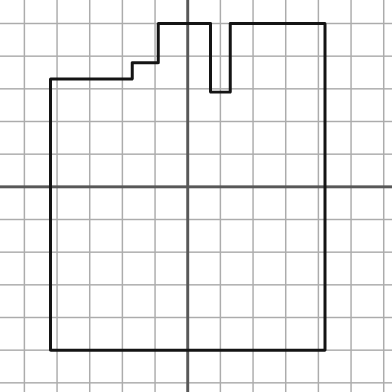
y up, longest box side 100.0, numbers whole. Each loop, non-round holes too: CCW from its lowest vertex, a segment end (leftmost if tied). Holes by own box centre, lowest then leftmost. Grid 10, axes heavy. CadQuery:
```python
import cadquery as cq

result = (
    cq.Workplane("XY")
    .moveTo(-42.0, -50.0)
    .lineTo(42.0, -50.0)
    .lineTo(42.0, 50.0)
    .lineTo(13.0, 50.0)
    .lineTo(13.0, 29.0)
    .lineTo(7.0, 29.0)
    .lineTo(7.0, 50.0)
    .lineTo(-9.0, 50.0)
    .lineTo(-9.0, 38.0)
    .lineTo(-17.0, 38.0)
    .lineTo(-17.0, 33.0)
    .lineTo(-42.0, 33.0)
    .close()
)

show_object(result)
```